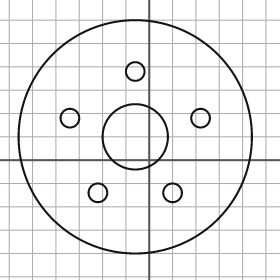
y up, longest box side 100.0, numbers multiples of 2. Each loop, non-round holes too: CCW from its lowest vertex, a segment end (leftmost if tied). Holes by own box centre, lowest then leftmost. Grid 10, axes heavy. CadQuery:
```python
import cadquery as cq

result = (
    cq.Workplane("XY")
    .moveTo(-6.0, 10.0)
    .circle(50.0)
    .moveTo(-22.0, -14.0)
    .circle(4.0)
    .moveTo(10.0, -14.0)
    .circle(4.0)
    .moveTo(-6.0, 10.0)
    .circle(14.0)
    .moveTo(-34.0, 18.0)
    .circle(4.0)
    .moveTo(22.0, 18.0)
    .circle(4.0)
    .moveTo(-6.0, 38.0)
    .circle(4.0)
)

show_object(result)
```